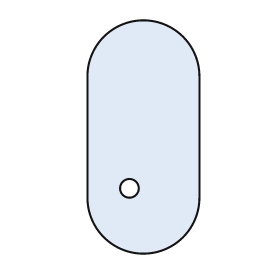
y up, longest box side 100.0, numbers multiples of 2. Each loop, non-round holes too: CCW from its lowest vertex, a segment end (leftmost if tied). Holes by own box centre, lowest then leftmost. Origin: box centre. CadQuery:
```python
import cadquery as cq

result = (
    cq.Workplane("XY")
    .moveTo(-24.0, -26.0)
    .threePointArc((0.0, -50.0), (24.0, -26.0))
    .lineTo(24.0, 26.0)
    .threePointArc((0.0, 50.0), (-24.0, 26.0))
    .close()
    .moveTo(-6.0, -22.0)
    .circle(4.0)
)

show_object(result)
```